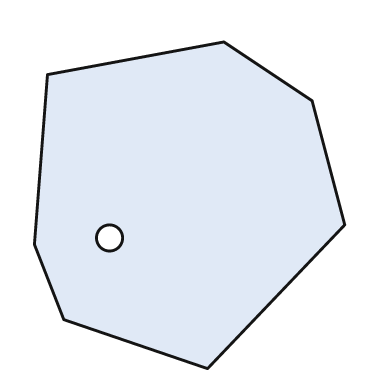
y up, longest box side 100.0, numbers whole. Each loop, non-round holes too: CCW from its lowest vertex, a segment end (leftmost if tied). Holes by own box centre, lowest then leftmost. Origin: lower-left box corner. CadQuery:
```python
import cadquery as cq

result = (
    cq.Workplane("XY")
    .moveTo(53.0, 0.0)
    .lineTo(95.0, 44.0)
    .lineTo(85.0, 82.0)
    .lineTo(58.0, 100.0)
    .lineTo(4.0, 90.0)
    .lineTo(0.0, 38.0)
    .lineTo(9.0, 15.0)
    .close()
    .moveTo(23.0, 40.0)
    .circle(4.0)
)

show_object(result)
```